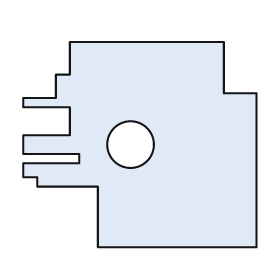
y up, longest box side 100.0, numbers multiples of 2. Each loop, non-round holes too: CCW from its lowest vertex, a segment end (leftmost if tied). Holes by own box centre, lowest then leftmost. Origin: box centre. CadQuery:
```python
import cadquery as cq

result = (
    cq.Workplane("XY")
    .moveTo(-18.0, -44.0)
    .lineTo(50.0, -44.0)
    .lineTo(50.0, 22.0)
    .lineTo(36.0, 22.0)
    .lineTo(36.0, 44.0)
    .lineTo(-30.0, 44.0)
    .lineTo(-30.0, 30.0)
    .lineTo(-36.0, 30.0)
    .lineTo(-36.0, 20.0)
    .lineTo(-50.0, 20.0)
    .lineTo(-50.0, 16.0)
    .lineTo(-30.0, 16.0)
    .lineTo(-30.0, 4.0)
    .lineTo(-50.0, 4.0)
    .lineTo(-50.0, -4.0)
    .lineTo(-26.0, -4.0)
    .lineTo(-26.0, -8.0)
    .lineTo(-50.0, -8.0)
    .lineTo(-50.0, -14.0)
    .lineTo(-44.0, -14.0)
    .lineTo(-44.0, -18.0)
    .lineTo(-18.0, -18.0)
    .close()
    .moveTo(-4.0, 0.0)
    .circle(10.0)
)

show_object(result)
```